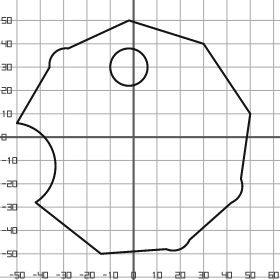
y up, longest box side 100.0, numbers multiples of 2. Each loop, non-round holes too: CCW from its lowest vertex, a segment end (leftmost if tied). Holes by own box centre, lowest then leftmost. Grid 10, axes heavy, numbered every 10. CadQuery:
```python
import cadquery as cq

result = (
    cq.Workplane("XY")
    .moveTo(-14.0, -50.0)
    .lineTo(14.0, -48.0)
    .threePointArc((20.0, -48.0), (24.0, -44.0))
    .lineTo(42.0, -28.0)
    .threePointArc((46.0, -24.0), (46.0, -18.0))
    .lineTo(50.0, 10.0)
    .lineTo(30.0, 40.0)
    .lineTo(-2.0, 50.0)
    .lineTo(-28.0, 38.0)
    .threePointArc((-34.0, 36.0), (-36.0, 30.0))
    .lineTo(-50.0, 6.0)
    .threePointArc((-34.0, -8.0), (-42.0, -28.0))
    .close()
    .moveTo(-2.0, 30.0)
    .circle(8.0)
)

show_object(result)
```